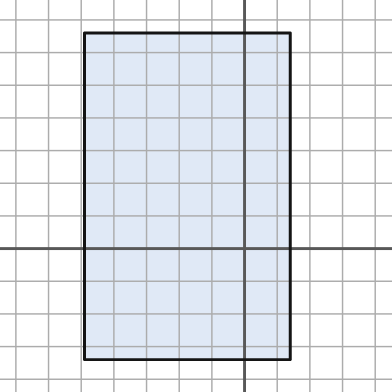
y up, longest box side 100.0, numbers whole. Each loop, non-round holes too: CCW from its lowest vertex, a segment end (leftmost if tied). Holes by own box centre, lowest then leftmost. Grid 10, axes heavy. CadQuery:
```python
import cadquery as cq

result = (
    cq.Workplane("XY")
    .moveTo(-49.0, -34.0)
    .lineTo(14.0, -34.0)
    .lineTo(14.0, 66.0)
    .lineTo(-49.0, 66.0)
    .close()
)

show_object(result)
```